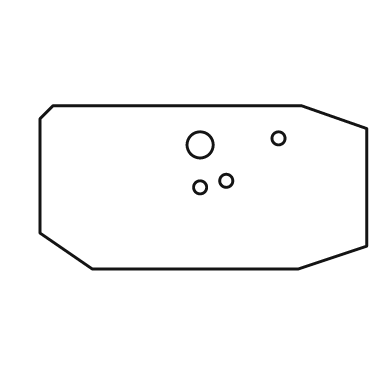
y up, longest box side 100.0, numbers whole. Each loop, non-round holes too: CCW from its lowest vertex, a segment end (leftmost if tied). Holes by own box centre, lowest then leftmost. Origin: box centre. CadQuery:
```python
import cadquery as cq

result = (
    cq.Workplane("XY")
    .moveTo(-34.0, -25.0)
    .lineTo(29.0, -25.0)
    .lineTo(50.0, -18.0)
    .lineTo(50.0, 18.0)
    .lineTo(30.0, 25.0)
    .lineTo(-46.0, 25.0)
    .lineTo(-50.0, 21.0)
    .lineTo(-50.0, -14.0)
    .close()
    .moveTo(-1.0, 0.0)
    .circle(2.0)
    .moveTo(7.0, 2.0)
    .circle(2.0)
    .moveTo(-1.0, 13.0)
    .circle(4.0)
    .moveTo(23.0, 15.0)
    .circle(2.0)
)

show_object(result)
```